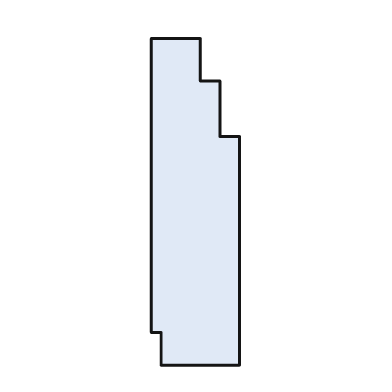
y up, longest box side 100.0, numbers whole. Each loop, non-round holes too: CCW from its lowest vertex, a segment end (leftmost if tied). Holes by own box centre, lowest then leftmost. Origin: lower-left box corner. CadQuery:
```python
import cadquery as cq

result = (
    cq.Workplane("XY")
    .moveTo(3.0, 0.0)
    .lineTo(27.0, 0.0)
    .lineTo(27.0, 70.0)
    .lineTo(21.0, 70.0)
    .lineTo(21.0, 87.0)
    .lineTo(15.0, 87.0)
    .lineTo(15.0, 100.0)
    .lineTo(0.0, 100.0)
    .lineTo(0.0, 10.0)
    .lineTo(3.0, 10.0)
    .close()
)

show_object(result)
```